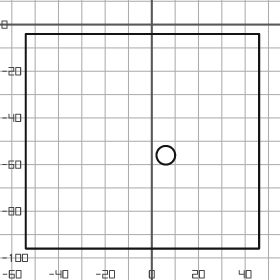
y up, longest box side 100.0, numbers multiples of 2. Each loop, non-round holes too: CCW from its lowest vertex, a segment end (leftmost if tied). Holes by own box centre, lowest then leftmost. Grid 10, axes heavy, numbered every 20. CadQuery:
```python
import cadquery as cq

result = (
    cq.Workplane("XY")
    .moveTo(-54.0, -96.0)
    .lineTo(46.0, -96.0)
    .lineTo(46.0, -4.0)
    .lineTo(-54.0, -4.0)
    .close()
    .moveTo(6.0, -56.0)
    .circle(4.0)
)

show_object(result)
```